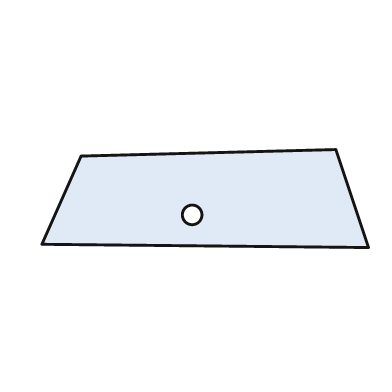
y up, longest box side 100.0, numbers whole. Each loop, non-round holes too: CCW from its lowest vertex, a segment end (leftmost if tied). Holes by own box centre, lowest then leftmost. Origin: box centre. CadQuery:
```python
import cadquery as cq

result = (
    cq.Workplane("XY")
    .moveTo(50.0, -15.0)
    .lineTo(40.0, 15.0)
    .lineTo(-38.0, 13.0)
    .lineTo(-50.0, -14.0)
    .close()
    .moveTo(-4.0, -5.0)
    .circle(3.0)
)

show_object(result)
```